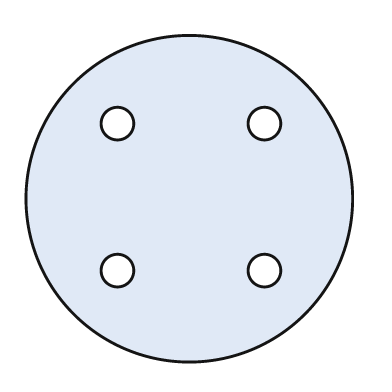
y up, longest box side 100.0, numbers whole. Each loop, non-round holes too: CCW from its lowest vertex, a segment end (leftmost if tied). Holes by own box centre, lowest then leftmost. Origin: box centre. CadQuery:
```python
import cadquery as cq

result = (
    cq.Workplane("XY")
    .moveTo(0.0, 0.0)
    .circle(50.0)
    .moveTo(-22.0, -22.0)
    .circle(5.0)
    .moveTo(23.0, -22.0)
    .circle(5.0)
    .moveTo(-22.0, 23.0)
    .circle(5.0)
    .moveTo(23.0, 23.0)
    .circle(5.0)
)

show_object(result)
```